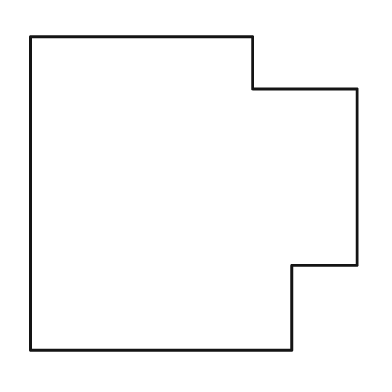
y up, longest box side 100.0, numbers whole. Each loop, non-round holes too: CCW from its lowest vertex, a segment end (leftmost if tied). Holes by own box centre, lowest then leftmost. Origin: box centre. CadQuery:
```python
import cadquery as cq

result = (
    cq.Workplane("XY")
    .moveTo(-50.0, -48.0)
    .lineTo(30.0, -48.0)
    .lineTo(30.0, -22.0)
    .lineTo(50.0, -22.0)
    .lineTo(50.0, 32.0)
    .lineTo(18.0, 32.0)
    .lineTo(18.0, 48.0)
    .lineTo(-50.0, 48.0)
    .close()
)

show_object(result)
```